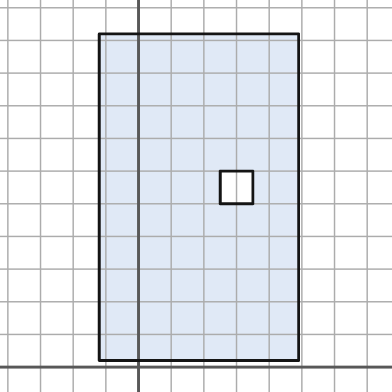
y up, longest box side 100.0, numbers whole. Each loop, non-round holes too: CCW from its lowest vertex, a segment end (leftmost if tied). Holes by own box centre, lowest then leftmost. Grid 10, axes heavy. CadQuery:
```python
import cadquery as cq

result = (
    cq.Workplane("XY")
    .moveTo(-12.0, 2.0)
    .lineTo(49.0, 2.0)
    .lineTo(49.0, 102.0)
    .lineTo(-12.0, 102.0)
    .close()
    .moveTo(25.0, 50.0)
    .lineTo(35.0, 50.0)
    .lineTo(35.0, 60.0)
    .lineTo(25.0, 60.0)
    .close()
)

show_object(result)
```